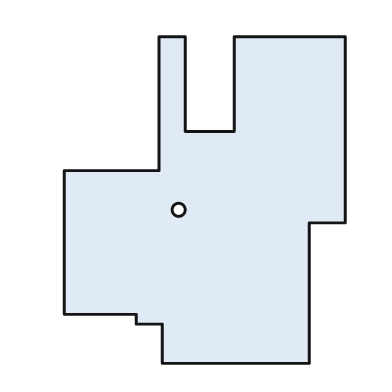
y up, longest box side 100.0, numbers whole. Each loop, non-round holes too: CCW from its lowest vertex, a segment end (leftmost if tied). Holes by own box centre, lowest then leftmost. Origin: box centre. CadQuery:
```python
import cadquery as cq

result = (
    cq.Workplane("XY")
    .moveTo(-13.0, -50.0)
    .lineTo(32.0, -50.0)
    .lineTo(32.0, -7.0)
    .lineTo(43.0, -7.0)
    .lineTo(43.0, 50.0)
    .lineTo(9.0, 50.0)
    .lineTo(9.0, 21.0)
    .lineTo(-6.0, 21.0)
    .lineTo(-6.0, 50.0)
    .lineTo(-14.0, 50.0)
    .lineTo(-14.0, 9.0)
    .lineTo(-43.0, 9.0)
    .lineTo(-43.0, -35.0)
    .lineTo(-21.0, -35.0)
    .lineTo(-21.0, -38.0)
    .lineTo(-13.0, -38.0)
    .close()
    .moveTo(-8.0, -3.0)
    .circle(2.0)
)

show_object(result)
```